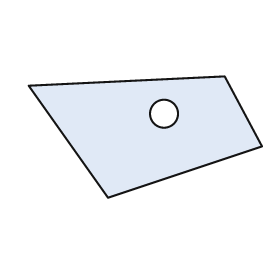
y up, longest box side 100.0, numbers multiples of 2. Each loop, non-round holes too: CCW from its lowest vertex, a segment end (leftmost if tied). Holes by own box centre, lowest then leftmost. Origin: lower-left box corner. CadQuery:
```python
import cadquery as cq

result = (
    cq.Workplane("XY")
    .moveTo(34.0, 0.0)
    .lineTo(100.0, 22.0)
    .lineTo(84.0, 52.0)
    .lineTo(0.0, 48.0)
    .close()
    .moveTo(58.0, 36.0)
    .circle(6.0)
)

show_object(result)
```